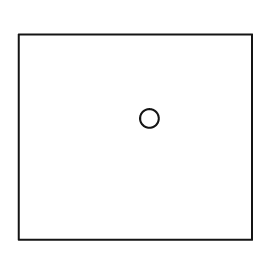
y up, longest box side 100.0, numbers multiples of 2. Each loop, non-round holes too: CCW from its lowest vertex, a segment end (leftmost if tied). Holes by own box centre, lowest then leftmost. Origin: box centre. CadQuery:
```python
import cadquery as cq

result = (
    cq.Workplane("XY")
    .moveTo(-50.0, -44.0)
    .lineTo(50.0, -44.0)
    .lineTo(50.0, 44.0)
    .lineTo(-50.0, 44.0)
    .close()
    .moveTo(6.0, 8.0)
    .circle(4.0)
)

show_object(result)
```